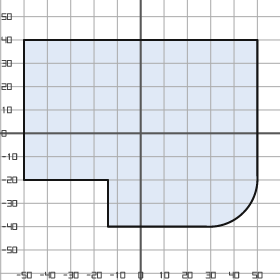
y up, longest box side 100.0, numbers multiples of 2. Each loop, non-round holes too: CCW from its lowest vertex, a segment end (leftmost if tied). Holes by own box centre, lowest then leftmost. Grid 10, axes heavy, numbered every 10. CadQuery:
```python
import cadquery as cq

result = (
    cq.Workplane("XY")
    .moveTo(-14.0, -40.0)
    .lineTo(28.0, -40.0)
    .threePointArc((44.0, -34.0), (50.0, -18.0))
    .lineTo(50.0, 40.0)
    .lineTo(-50.0, 40.0)
    .lineTo(-50.0, -20.0)
    .lineTo(-14.0, -20.0)
    .close()
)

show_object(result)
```